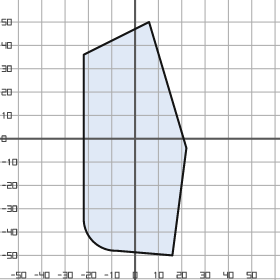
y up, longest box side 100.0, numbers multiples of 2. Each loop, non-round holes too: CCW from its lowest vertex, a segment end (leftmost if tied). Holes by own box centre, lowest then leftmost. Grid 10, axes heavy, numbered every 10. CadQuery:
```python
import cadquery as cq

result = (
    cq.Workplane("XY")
    .moveTo(16.0, -50.0)
    .lineTo(22.0, -4.0)
    .lineTo(6.0, 50.0)
    .lineTo(-22.0, 36.0)
    .lineTo(-22.0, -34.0)
    .threePointArc((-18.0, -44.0), (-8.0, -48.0))
    .close()
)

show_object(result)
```